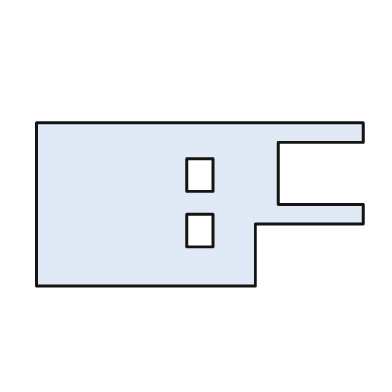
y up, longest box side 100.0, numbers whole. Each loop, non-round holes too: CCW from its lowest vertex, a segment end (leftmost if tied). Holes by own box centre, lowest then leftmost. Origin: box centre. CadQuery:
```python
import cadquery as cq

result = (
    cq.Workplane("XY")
    .moveTo(-50.0, -25.0)
    .lineTo(17.0, -25.0)
    .lineTo(17.0, -6.0)
    .lineTo(50.0, -6.0)
    .lineTo(50.0, 0.0)
    .lineTo(24.0, 0.0)
    .lineTo(24.0, 19.0)
    .lineTo(50.0, 19.0)
    .lineTo(50.0, 25.0)
    .lineTo(-50.0, 25.0)
    .close()
    .moveTo(-4.0, -13.0)
    .lineTo(4.0, -13.0)
    .lineTo(4.0, -3.0)
    .lineTo(-4.0, -3.0)
    .close()
    .moveTo(-4.0, 4.0)
    .lineTo(4.0, 4.0)
    .lineTo(4.0, 14.0)
    .lineTo(-4.0, 14.0)
    .close()
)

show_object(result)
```